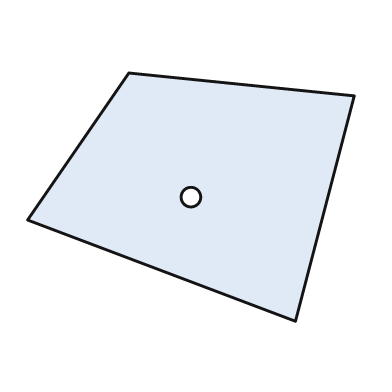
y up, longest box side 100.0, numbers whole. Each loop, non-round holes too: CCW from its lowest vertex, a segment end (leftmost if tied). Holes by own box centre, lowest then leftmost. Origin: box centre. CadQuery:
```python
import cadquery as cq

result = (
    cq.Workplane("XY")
    .moveTo(32.0, -38.0)
    .lineTo(50.0, 31.0)
    .lineTo(-19.0, 38.0)
    .lineTo(-50.0, -7.0)
    .close()
    .moveTo(0.0, 0.0)
    .circle(3.0)
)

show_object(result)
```